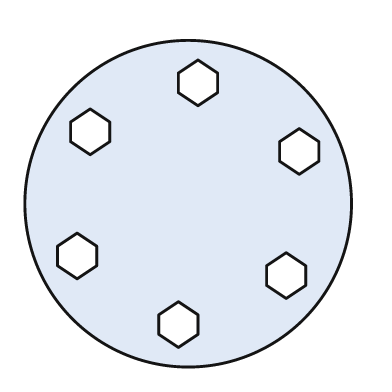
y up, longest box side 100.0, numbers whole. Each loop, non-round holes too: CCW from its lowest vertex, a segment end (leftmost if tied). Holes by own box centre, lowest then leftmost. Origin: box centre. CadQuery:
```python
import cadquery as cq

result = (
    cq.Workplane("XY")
    .moveTo(0.0, 0.0)
    .circle(50.0)
    .moveTo(-3.0, -44.0)
    .lineTo(3.0, -40.0)
    .lineTo(3.0, -34.0)
    .lineTo(-3.0, -30.0)
    .lineTo(-9.0, -34.0)
    .lineTo(-9.0, -40.0)
    .close()
    .moveTo(30.0, -29.0)
    .lineTo(36.0, -25.0)
    .lineTo(36.0, -19.0)
    .lineTo(30.0, -15.0)
    .lineTo(24.0, -19.0)
    .lineTo(24.0, -25.0)
    .close()
    .moveTo(-34.0, -23.0)
    .lineTo(-28.0, -19.0)
    .lineTo(-28.0, -13.0)
    .lineTo(-34.0, -9.0)
    .lineTo(-40.0, -13.0)
    .lineTo(-40.0, -19.0)
    .close()
    .moveTo(34.0, 9.0)
    .lineTo(40.0, 13.0)
    .lineTo(40.0, 19.0)
    .lineTo(34.0, 23.0)
    .lineTo(28.0, 19.0)
    .lineTo(28.0, 13.0)
    .close()
    .moveTo(-30.0, 15.0)
    .lineTo(-24.0, 19.0)
    .lineTo(-24.0, 25.0)
    .lineTo(-30.0, 29.0)
    .lineTo(-36.0, 25.0)
    .lineTo(-36.0, 19.0)
    .close()
    .moveTo(3.0, 30.0)
    .lineTo(9.0, 34.0)
    .lineTo(9.0, 40.0)
    .lineTo(3.0, 44.0)
    .lineTo(-3.0, 40.0)
    .lineTo(-3.0, 34.0)
    .close()
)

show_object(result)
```